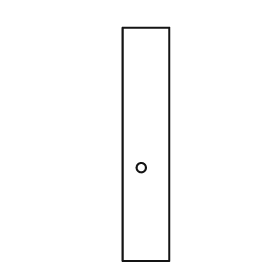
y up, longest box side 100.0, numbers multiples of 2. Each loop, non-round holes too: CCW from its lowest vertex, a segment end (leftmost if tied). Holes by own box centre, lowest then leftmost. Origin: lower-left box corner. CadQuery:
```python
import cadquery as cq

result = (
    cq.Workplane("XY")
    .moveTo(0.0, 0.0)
    .lineTo(20.0, 0.0)
    .lineTo(20.0, 100.0)
    .lineTo(0.0, 100.0)
    .close()
    .moveTo(8.0, 40.0)
    .circle(2.0)
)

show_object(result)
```